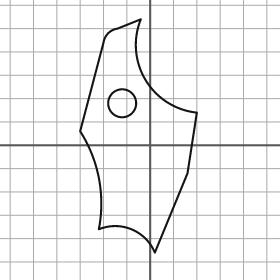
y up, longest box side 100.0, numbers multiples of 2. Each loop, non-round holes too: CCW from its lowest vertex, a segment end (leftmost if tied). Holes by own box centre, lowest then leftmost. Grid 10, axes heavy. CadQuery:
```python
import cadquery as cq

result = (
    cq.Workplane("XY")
    .moveTo(2.0, -46.0)
    .lineTo(16.0, -12.0)
    .lineTo(20.0, 14.0)
    .threePointArc((-2.0, 28.0), (-4.0, 54.0))
    .lineTo(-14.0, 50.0)
    .threePointArc((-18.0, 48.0), (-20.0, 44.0))
    .lineTo(-30.0, 6.0)
    .threePointArc((-22.0, -14.0), (-22.0, -36.0))
    .threePointArc((-8.0, -36.0), (2.0, -46.0))
    .close()
    .moveTo(-12.0, 18.0)
    .circle(6.0)
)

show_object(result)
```